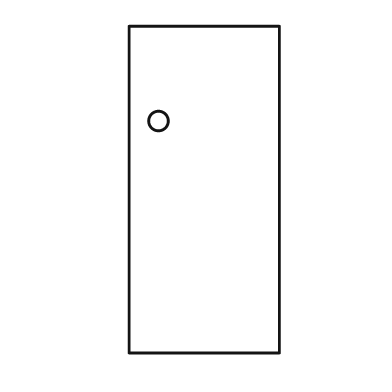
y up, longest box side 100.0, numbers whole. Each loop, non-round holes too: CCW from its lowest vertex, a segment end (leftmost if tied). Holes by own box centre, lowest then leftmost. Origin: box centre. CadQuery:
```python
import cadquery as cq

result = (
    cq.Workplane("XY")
    .moveTo(-23.0, -50.0)
    .lineTo(23.0, -50.0)
    .lineTo(23.0, 50.0)
    .lineTo(-23.0, 50.0)
    .close()
    .moveTo(-14.0, 21.0)
    .circle(3.0)
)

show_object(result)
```